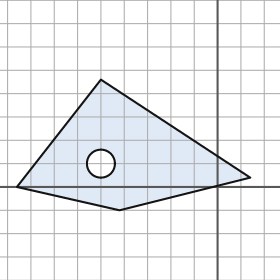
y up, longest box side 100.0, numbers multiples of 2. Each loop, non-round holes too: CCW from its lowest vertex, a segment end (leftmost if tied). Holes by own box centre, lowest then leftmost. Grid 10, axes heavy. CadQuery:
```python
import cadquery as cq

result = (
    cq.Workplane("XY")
    .moveTo(-42.0, -10.0)
    .lineTo(14.0, 4.0)
    .lineTo(-50.0, 46.0)
    .lineTo(-86.0, 0.0)
    .close()
    .moveTo(-50.0, 10.0)
    .circle(6.0)
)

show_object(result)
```